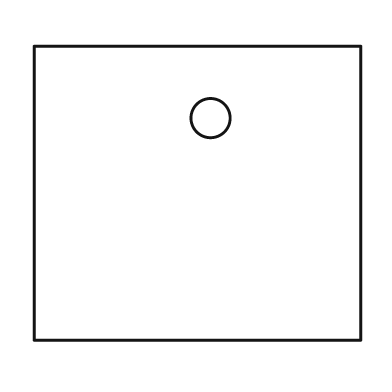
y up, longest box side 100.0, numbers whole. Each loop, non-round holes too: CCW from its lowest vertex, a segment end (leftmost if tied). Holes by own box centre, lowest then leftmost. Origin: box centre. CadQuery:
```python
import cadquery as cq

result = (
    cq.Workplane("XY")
    .moveTo(-50.0, -45.0)
    .lineTo(50.0, -45.0)
    .lineTo(50.0, 45.0)
    .lineTo(-50.0, 45.0)
    .close()
    .moveTo(4.0, 23.0)
    .circle(6.0)
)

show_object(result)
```